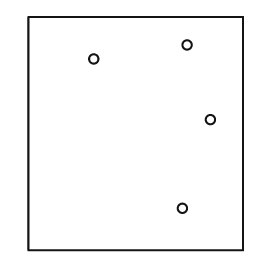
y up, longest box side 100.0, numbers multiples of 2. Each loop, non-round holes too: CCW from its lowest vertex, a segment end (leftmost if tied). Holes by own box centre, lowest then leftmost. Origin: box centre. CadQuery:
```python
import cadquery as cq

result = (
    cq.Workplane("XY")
    .moveTo(-46.0, -50.0)
    .lineTo(46.0, -50.0)
    .lineTo(46.0, 50.0)
    .lineTo(-46.0, 50.0)
    .close()
    .moveTo(20.0, -32.0)
    .circle(2.0)
    .moveTo(32.0, 6.0)
    .circle(2.0)
    .moveTo(-18.0, 32.0)
    .circle(2.0)
    .moveTo(22.0, 38.0)
    .circle(2.0)
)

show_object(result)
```